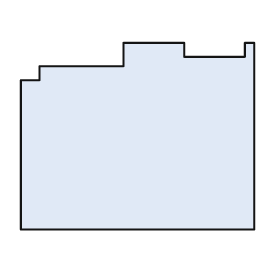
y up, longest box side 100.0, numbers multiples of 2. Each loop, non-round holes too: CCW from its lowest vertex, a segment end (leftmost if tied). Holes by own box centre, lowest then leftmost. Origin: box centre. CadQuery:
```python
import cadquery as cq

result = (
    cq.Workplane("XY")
    .moveTo(-50.0, -40.0)
    .lineTo(50.0, -40.0)
    .lineTo(50.0, 40.0)
    .lineTo(46.0, 40.0)
    .lineTo(46.0, 34.0)
    .lineTo(20.0, 34.0)
    .lineTo(20.0, 40.0)
    .lineTo(-6.0, 40.0)
    .lineTo(-6.0, 30.0)
    .lineTo(-42.0, 30.0)
    .lineTo(-42.0, 24.0)
    .lineTo(-50.0, 24.0)
    .close()
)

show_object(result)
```